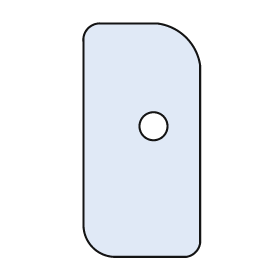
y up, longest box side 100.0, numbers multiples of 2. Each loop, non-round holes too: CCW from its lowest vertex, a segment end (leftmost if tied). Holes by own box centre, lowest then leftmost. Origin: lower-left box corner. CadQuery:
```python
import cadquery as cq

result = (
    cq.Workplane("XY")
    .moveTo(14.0, 0.0)
    .lineTo(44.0, 0.0)
    .threePointArc((48.0, 2.0), (50.0, 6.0))
    .lineTo(50.0, 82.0)
    .threePointArc((44.0, 94.0), (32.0, 100.0))
    .lineTo(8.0, 100.0)
    .threePointArc((2.0, 98.0), (0.0, 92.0))
    .lineTo(0.0, 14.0)
    .threePointArc((4.0, 4.0), (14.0, 0.0))
    .close()
    .moveTo(30.0, 56.0)
    .circle(6.0)
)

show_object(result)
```